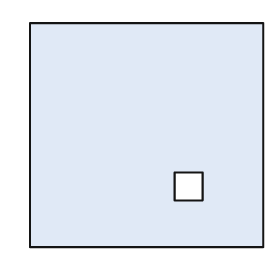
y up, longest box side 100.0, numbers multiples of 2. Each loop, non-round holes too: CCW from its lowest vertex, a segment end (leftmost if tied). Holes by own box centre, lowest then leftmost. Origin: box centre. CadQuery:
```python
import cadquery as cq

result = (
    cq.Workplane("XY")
    .moveTo(-50.0, -48.0)
    .lineTo(50.0, -48.0)
    .lineTo(50.0, 48.0)
    .lineTo(-50.0, 48.0)
    .close()
    .moveTo(12.0, -28.0)
    .lineTo(24.0, -28.0)
    .lineTo(24.0, -16.0)
    .lineTo(12.0, -16.0)
    .close()
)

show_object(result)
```